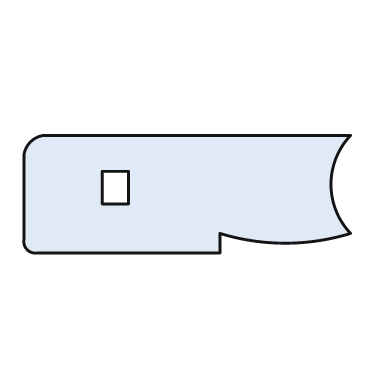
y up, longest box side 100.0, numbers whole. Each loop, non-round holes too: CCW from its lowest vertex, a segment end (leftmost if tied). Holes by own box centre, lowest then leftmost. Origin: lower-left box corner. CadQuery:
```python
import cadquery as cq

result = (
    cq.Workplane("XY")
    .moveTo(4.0, 0.0)
    .lineTo(60.0, 0.0)
    .lineTo(60.0, 6.0)
    .threePointArc((80.0, 3.0), (100.0, 6.0))
    .threePointArc((94.0, 21.0), (100.0, 36.0))
    .lineTo(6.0, 36.0)
    .threePointArc((2.0, 34.0), (0.0, 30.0))
    .lineTo(0.0, 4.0)
    .threePointArc((1.0, 1.0), (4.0, 0.0))
    .close()
    .moveTo(24.0, 15.0)
    .lineTo(32.0, 15.0)
    .lineTo(32.0, 25.0)
    .lineTo(24.0, 25.0)
    .close()
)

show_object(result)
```